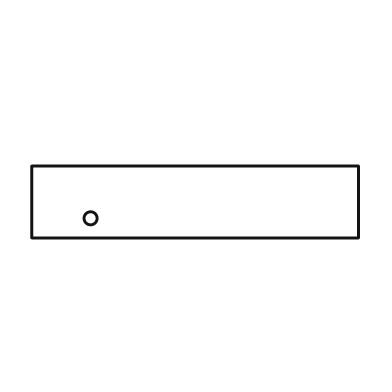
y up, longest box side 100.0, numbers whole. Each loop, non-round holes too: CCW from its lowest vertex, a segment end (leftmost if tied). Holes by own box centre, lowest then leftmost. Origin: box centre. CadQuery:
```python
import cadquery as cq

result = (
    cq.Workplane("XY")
    .moveTo(-50.0, -11.0)
    .lineTo(50.0, -11.0)
    .lineTo(50.0, 11.0)
    .lineTo(-50.0, 11.0)
    .close()
    .moveTo(-32.0, -5.0)
    .circle(2.0)
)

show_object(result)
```